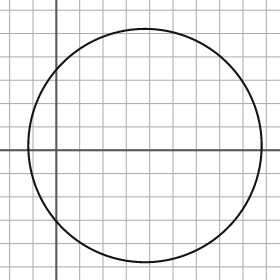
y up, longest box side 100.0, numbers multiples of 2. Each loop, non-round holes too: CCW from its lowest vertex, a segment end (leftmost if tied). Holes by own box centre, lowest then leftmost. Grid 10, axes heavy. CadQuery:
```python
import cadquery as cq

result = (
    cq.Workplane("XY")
    .moveTo(38.0, 2.0)
    .circle(50.0)
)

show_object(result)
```